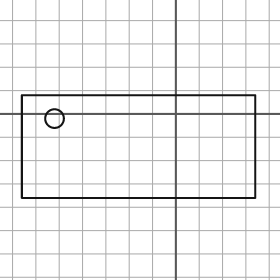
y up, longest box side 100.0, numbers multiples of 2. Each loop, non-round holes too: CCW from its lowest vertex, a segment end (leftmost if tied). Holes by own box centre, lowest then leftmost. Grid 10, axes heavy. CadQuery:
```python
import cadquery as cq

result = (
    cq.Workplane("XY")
    .moveTo(-66.0, -36.0)
    .lineTo(34.0, -36.0)
    .lineTo(34.0, 8.0)
    .lineTo(-66.0, 8.0)
    .close()
    .moveTo(-52.0, -2.0)
    .circle(4.0)
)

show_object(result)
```